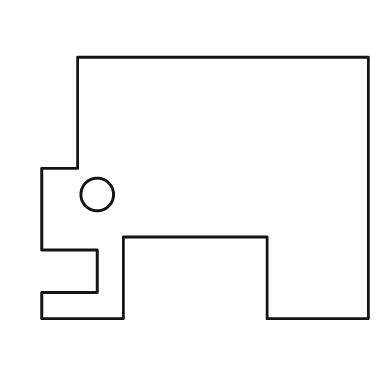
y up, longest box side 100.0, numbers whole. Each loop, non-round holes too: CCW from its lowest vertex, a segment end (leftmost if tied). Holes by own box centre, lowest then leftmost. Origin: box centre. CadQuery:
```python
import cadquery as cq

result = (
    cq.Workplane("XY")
    .moveTo(-50.0, -40.0)
    .lineTo(-25.0, -40.0)
    .lineTo(-25.0, -15.0)
    .lineTo(19.0, -15.0)
    .lineTo(19.0, -40.0)
    .lineTo(50.0, -40.0)
    .lineTo(50.0, 40.0)
    .lineTo(-39.0, 40.0)
    .lineTo(-39.0, 6.0)
    .lineTo(-50.0, 6.0)
    .lineTo(-50.0, -19.0)
    .lineTo(-33.0, -19.0)
    .lineTo(-33.0, -32.0)
    .lineTo(-50.0, -32.0)
    .close()
    .moveTo(-33.0, -2.0)
    .circle(5.0)
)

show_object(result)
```